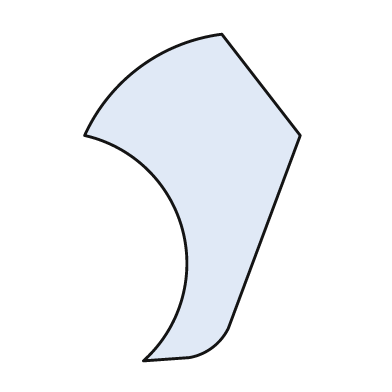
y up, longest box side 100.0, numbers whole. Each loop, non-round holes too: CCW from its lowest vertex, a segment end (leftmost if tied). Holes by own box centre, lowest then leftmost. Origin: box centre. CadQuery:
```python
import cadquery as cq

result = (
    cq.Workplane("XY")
    .moveTo(-15.0, -50.0)
    .lineTo(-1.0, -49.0)
    .threePointArc((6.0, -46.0), (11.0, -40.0))
    .lineTo(33.0, 19.0)
    .lineTo(9.0, 50.0)
    .threePointArc((-16.0, 40.0), (-33.0, 19.0))
    .threePointArc((-3.0, -10.0), (-15.0, -50.0))
    .close()
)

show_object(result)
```